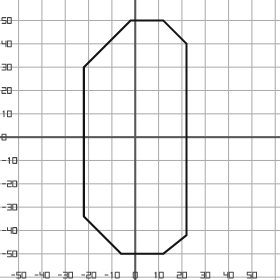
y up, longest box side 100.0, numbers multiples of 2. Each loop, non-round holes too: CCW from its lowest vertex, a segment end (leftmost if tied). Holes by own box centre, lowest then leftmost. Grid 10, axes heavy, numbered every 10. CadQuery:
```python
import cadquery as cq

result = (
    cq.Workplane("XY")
    .moveTo(-6.0, -50.0)
    .lineTo(12.0, -50.0)
    .lineTo(22.0, -42.0)
    .lineTo(22.0, 40.0)
    .lineTo(12.0, 50.0)
    .lineTo(-2.0, 50.0)
    .lineTo(-22.0, 30.0)
    .lineTo(-22.0, -34.0)
    .close()
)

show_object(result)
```